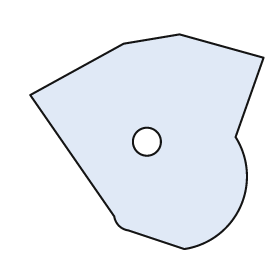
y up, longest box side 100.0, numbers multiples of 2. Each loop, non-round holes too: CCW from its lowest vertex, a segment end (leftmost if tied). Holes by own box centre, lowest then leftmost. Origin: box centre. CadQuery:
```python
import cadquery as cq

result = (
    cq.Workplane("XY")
    .moveTo(16.0, -46.0)
    .threePointArc((40.0, -28.0), (38.0, 2.0))
    .lineTo(50.0, 36.0)
    .lineTo(14.0, 46.0)
    .lineTo(-10.0, 42.0)
    .lineTo(-50.0, 20.0)
    .lineTo(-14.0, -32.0)
    .threePointArc((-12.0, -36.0), (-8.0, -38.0))
    .close()
    .moveTo(0.0, 0.0)
    .circle(6.0)
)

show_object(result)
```